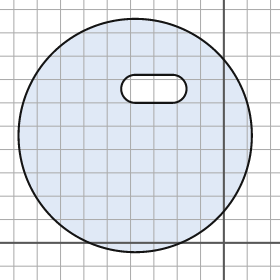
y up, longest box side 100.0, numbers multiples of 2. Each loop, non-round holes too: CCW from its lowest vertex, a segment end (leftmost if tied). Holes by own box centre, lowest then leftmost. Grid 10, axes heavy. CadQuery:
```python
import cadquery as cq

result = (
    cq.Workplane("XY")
    .moveTo(-38.0, 46.0)
    .circle(50.0)
    .moveTo(-38.0, 60.0)
    .lineTo(-22.0, 60.0)
    .threePointArc((-16.0, 66.0), (-22.0, 72.0))
    .lineTo(-38.0, 72.0)
    .threePointArc((-44.0, 66.0), (-38.0, 60.0))
    .close()
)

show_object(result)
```